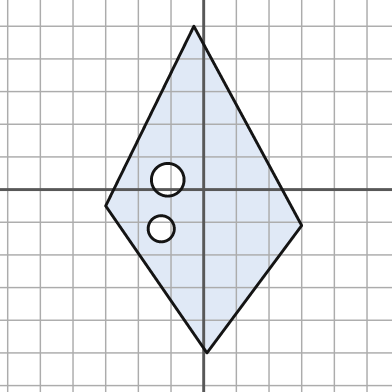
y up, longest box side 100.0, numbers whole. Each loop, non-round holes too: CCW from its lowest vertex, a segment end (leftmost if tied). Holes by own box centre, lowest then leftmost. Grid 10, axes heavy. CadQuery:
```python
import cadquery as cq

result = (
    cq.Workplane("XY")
    .moveTo(1.0, -50.0)
    .lineTo(30.0, -11.0)
    .lineTo(-3.0, 50.0)
    .lineTo(-30.0, -5.0)
    .close()
    .moveTo(-13.0, -12.0)
    .circle(4.0)
    .moveTo(-11.0, 3.0)
    .circle(5.0)
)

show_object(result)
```